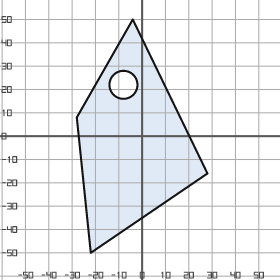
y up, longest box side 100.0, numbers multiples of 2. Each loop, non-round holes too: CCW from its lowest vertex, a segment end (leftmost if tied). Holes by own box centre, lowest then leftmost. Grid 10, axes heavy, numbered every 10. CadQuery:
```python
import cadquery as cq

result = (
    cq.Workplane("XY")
    .moveTo(-22.0, -50.0)
    .lineTo(28.0, -16.0)
    .lineTo(-4.0, 50.0)
    .lineTo(-28.0, 8.0)
    .close()
    .moveTo(-8.0, 22.0)
    .circle(6.0)
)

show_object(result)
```